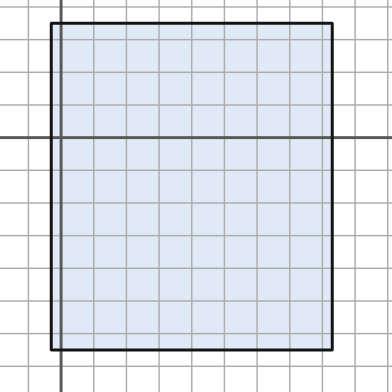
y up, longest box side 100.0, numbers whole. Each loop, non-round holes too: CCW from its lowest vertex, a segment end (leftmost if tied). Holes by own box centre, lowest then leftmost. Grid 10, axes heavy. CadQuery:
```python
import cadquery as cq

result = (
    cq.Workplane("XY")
    .moveTo(-3.0, -65.0)
    .lineTo(83.0, -65.0)
    .lineTo(83.0, 35.0)
    .lineTo(-3.0, 35.0)
    .close()
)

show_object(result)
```